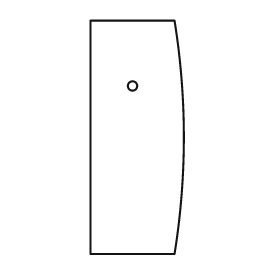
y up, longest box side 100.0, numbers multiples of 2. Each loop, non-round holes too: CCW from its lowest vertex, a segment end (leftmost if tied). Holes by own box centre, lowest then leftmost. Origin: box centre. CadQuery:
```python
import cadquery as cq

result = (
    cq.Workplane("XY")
    .moveTo(-20.0, -50.0)
    .lineTo(16.0, -50.0)
    .threePointArc((20.0, 0.0), (16.0, 50.0))
    .lineTo(-20.0, 50.0)
    .close()
    .moveTo(-2.0, 22.0)
    .circle(2.0)
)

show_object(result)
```